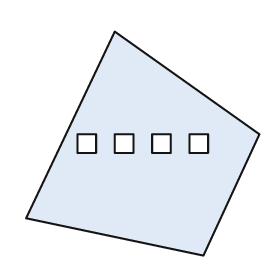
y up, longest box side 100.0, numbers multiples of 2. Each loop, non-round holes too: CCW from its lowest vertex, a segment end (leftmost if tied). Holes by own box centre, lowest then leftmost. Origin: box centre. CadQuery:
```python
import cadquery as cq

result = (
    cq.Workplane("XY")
    .moveTo(26.0, -48.0)
    .lineTo(50.0, 4.0)
    .lineTo(-12.0, 48.0)
    .lineTo(-50.0, -32.0)
    .close()
    .moveTo(-28.0, -4.0)
    .lineTo(-20.0, -4.0)
    .lineTo(-20.0, 4.0)
    .lineTo(-28.0, 4.0)
    .close()
    .moveTo(-12.0, -4.0)
    .lineTo(-4.0, -4.0)
    .lineTo(-4.0, 4.0)
    .lineTo(-12.0, 4.0)
    .close()
    .moveTo(4.0, -4.0)
    .lineTo(12.0, -4.0)
    .lineTo(12.0, 4.0)
    .lineTo(4.0, 4.0)
    .close()
    .moveTo(20.0, -4.0)
    .lineTo(28.0, -4.0)
    .lineTo(28.0, 4.0)
    .lineTo(20.0, 4.0)
    .close()
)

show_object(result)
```